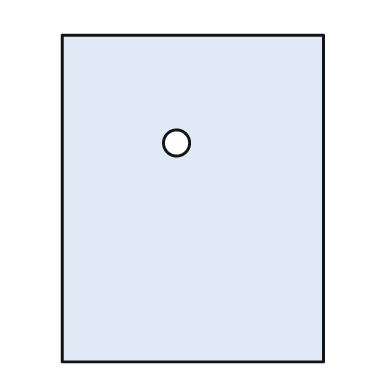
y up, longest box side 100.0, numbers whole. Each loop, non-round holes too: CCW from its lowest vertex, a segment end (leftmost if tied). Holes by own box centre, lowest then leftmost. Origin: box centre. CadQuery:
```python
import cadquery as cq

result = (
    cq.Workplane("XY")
    .moveTo(-40.0, -50.0)
    .lineTo(40.0, -50.0)
    .lineTo(40.0, 50.0)
    .lineTo(-40.0, 50.0)
    .close()
    .moveTo(-5.0, 17.0)
    .circle(4.0)
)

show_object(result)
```